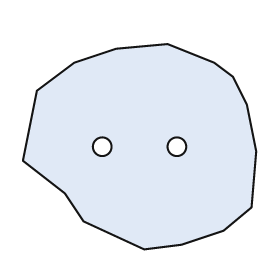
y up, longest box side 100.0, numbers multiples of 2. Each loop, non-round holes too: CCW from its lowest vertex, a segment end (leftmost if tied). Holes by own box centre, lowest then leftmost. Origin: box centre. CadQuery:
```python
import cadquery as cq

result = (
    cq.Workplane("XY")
    .moveTo(2.0, -44.0)
    .lineTo(18.0, -42.0)
    .lineTo(36.0, -36.0)
    .lineTo(48.0, -26.0)
    .lineTo(50.0, -2.0)
    .lineTo(46.0, 18.0)
    .lineTo(40.0, 30.0)
    .lineTo(32.0, 36.0)
    .lineTo(12.0, 44.0)
    .lineTo(-10.0, 42.0)
    .lineTo(-28.0, 36.0)
    .lineTo(-44.0, 24.0)
    .lineTo(-50.0, -6.0)
    .lineTo(-32.0, -20.0)
    .lineTo(-24.0, -32.0)
    .close()
    .moveTo(-16.0, 0.0)
    .circle(4.0)
    .moveTo(16.0, 0.0)
    .circle(4.0)
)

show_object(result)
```